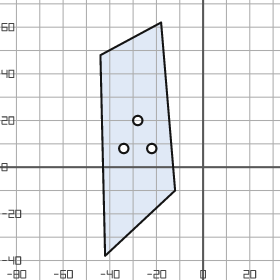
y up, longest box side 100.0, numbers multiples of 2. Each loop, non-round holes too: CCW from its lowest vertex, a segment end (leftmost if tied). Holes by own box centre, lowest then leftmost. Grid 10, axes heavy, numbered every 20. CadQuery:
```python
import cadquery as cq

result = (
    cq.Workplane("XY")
    .moveTo(-42.0, -38.0)
    .lineTo(-12.0, -10.0)
    .lineTo(-18.0, 62.0)
    .lineTo(-44.0, 48.0)
    .close()
    .moveTo(-34.0, 8.0)
    .circle(2.0)
    .moveTo(-22.0, 8.0)
    .circle(2.0)
    .moveTo(-28.0, 20.0)
    .circle(2.0)
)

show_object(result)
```